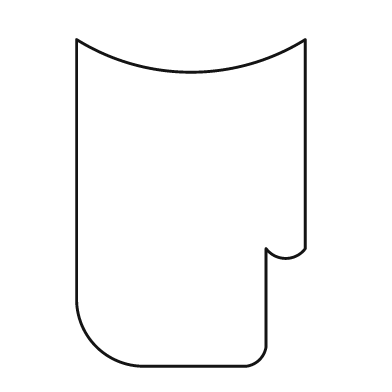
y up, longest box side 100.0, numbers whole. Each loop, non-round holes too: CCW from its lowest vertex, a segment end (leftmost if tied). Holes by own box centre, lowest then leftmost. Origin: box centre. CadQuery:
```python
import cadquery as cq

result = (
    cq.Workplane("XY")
    .moveTo(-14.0, -50.0)
    .lineTo(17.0, -50.0)
    .threePointArc((21.0, -48.0), (23.0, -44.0))
    .lineTo(23.0, -14.0)
    .threePointArc((29.0, -17.0), (35.0, -14.0))
    .lineTo(35.0, 50.0)
    .threePointArc((0.0, 40.0), (-35.0, 50.0))
    .lineTo(-35.0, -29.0)
    .threePointArc((-29.0, -44.0), (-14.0, -50.0))
    .close()
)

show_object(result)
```